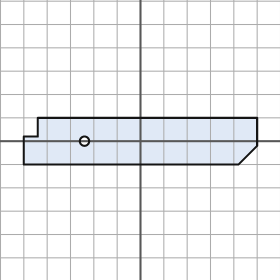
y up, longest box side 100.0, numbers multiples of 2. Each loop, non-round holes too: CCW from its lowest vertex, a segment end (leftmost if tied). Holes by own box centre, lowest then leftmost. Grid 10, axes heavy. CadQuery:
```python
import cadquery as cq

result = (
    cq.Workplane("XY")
    .moveTo(-50.0, -10.0)
    .lineTo(42.0, -10.0)
    .lineTo(50.0, -2.0)
    .lineTo(50.0, 10.0)
    .lineTo(-44.0, 10.0)
    .lineTo(-44.0, 2.0)
    .lineTo(-50.0, 2.0)
    .close()
    .moveTo(-24.0, 0.0)
    .circle(2.0)
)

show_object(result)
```